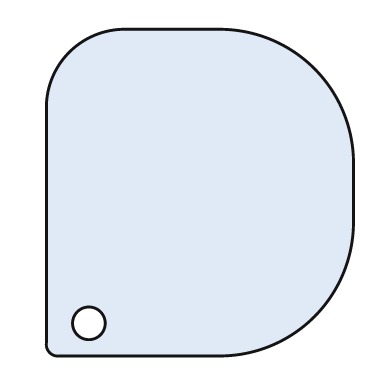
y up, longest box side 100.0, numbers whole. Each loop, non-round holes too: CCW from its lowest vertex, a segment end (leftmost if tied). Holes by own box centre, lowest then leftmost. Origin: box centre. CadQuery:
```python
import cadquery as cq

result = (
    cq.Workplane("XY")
    .moveTo(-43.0, -50.0)
    .lineTo(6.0, -50.0)
    .threePointArc((35.0, -38.0), (47.0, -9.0))
    .lineTo(47.0, 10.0)
    .threePointArc((35.0, 38.0), (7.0, 50.0))
    .lineTo(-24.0, 50.0)
    .threePointArc((-40.0, 43.0), (-47.0, 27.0))
    .lineTo(-47.0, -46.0)
    .threePointArc((-46.0, -49.0), (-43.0, -50.0))
    .close()
    .moveTo(-34.0, -40.0)
    .circle(5.0)
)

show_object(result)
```